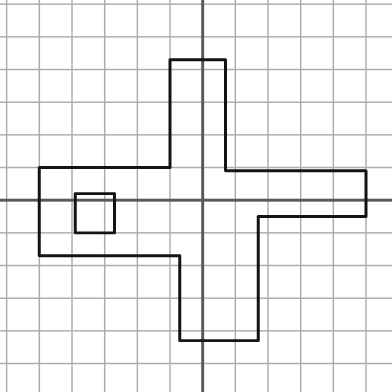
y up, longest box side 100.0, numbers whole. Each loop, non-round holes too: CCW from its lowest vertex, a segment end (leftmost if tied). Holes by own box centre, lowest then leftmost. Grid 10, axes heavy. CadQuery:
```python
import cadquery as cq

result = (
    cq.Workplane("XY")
    .moveTo(-7.0, -43.0)
    .lineTo(17.0, -43.0)
    .lineTo(17.0, -5.0)
    .lineTo(50.0, -5.0)
    .lineTo(50.0, 9.0)
    .lineTo(7.0, 9.0)
    .lineTo(7.0, 43.0)
    .lineTo(-10.0, 43.0)
    .lineTo(-10.0, 10.0)
    .lineTo(-50.0, 10.0)
    .lineTo(-50.0, -17.0)
    .lineTo(-7.0, -17.0)
    .close()
    .moveTo(-39.0, -10.0)
    .lineTo(-27.0, -10.0)
    .lineTo(-27.0, 2.0)
    .lineTo(-39.0, 2.0)
    .close()
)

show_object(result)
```